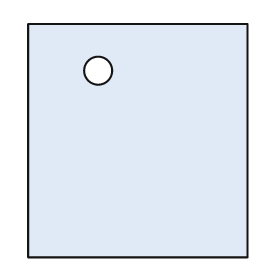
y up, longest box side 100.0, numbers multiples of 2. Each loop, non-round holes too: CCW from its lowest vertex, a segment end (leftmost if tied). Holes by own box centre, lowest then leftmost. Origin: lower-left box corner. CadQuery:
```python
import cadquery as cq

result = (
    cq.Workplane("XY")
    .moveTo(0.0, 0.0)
    .lineTo(94.0, 0.0)
    .lineTo(94.0, 100.0)
    .lineTo(0.0, 100.0)
    .close()
    .moveTo(30.0, 80.0)
    .circle(6.0)
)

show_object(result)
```